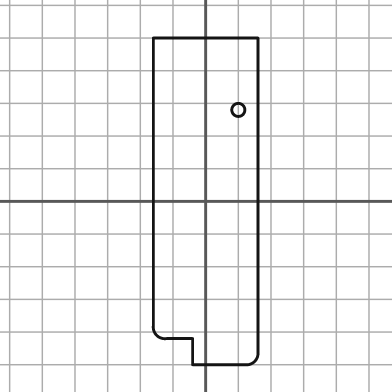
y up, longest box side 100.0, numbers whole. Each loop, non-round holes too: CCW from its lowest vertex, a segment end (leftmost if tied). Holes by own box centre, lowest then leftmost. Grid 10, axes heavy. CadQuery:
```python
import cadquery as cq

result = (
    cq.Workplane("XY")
    .moveTo(-4.0, -50.0)
    .lineTo(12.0, -50.0)
    .threePointArc((15.0, -49.0), (16.0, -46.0))
    .lineTo(16.0, 50.0)
    .lineTo(-16.0, 50.0)
    .lineTo(-16.0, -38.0)
    .threePointArc((-15.0, -41.0), (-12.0, -42.0))
    .lineTo(-4.0, -42.0)
    .close()
    .moveTo(10.0, 28.0)
    .circle(2.0)
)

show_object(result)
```